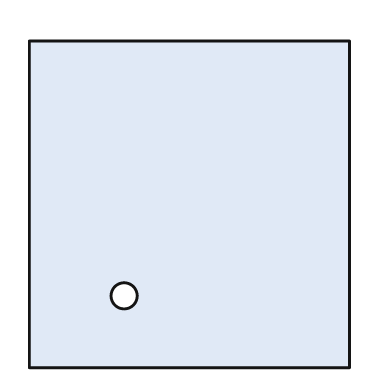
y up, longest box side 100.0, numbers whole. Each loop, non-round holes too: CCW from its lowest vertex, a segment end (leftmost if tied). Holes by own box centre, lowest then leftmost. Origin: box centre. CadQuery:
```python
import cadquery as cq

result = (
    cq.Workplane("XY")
    .moveTo(-49.0, -50.0)
    .lineTo(49.0, -50.0)
    .lineTo(49.0, 50.0)
    .lineTo(-49.0, 50.0)
    .close()
    .moveTo(-20.0, -28.0)
    .circle(4.0)
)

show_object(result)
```